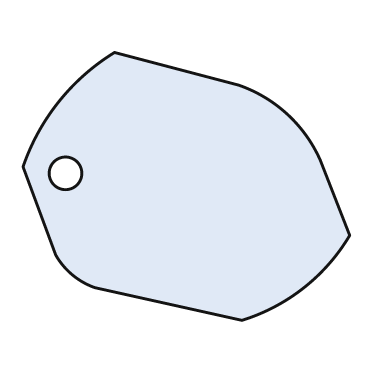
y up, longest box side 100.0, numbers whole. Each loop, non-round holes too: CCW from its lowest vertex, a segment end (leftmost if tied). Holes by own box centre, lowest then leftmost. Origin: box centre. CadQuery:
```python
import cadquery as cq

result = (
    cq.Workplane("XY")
    .moveTo(17.0, -41.0)
    .threePointArc((36.0, -31.0), (50.0, -15.0))
    .lineTo(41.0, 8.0)
    .threePointArc((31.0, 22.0), (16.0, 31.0))
    .lineTo(-22.0, 41.0)
    .threePointArc((-39.0, 26.0), (-50.0, 6.0))
    .lineTo(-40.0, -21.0)
    .threePointArc((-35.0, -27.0), (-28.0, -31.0))
    .close()
    .moveTo(-37.0, 4.0)
    .circle(5.0)
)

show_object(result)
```